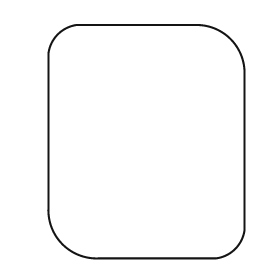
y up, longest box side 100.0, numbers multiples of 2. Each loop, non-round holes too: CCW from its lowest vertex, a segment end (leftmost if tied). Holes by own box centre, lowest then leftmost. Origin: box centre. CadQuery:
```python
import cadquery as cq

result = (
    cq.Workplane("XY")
    .moveTo(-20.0, -50.0)
    .lineTo(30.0, -50.0)
    .threePointArc((38.0, -46.0), (42.0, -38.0))
    .lineTo(42.0, 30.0)
    .threePointArc((36.0, 44.0), (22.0, 50.0))
    .lineTo(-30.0, 50.0)
    .threePointArc((-38.0, 46.0), (-42.0, 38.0))
    .lineTo(-42.0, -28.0)
    .threePointArc((-36.0, -44.0), (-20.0, -50.0))
    .close()
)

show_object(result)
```